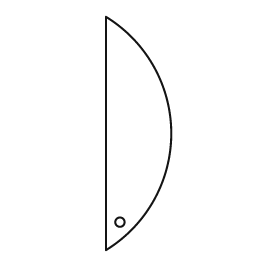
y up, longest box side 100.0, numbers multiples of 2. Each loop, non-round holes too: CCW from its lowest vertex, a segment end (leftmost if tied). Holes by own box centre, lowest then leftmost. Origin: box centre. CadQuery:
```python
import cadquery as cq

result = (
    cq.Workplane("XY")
    .moveTo(-14.0, -50.0)
    .threePointArc((14.0, 0.0), (-14.0, 50.0))
    .close()
    .moveTo(-8.0, -38.0)
    .circle(2.0)
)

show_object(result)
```